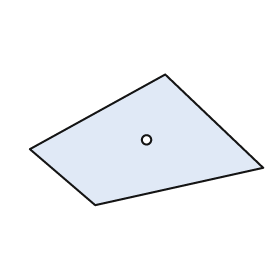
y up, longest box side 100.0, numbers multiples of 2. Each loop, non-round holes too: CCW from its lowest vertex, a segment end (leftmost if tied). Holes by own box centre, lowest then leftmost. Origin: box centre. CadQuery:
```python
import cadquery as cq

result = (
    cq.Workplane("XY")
    .moveTo(-22.0, -28.0)
    .lineTo(50.0, -12.0)
    .lineTo(8.0, 28.0)
    .lineTo(-50.0, -4.0)
    .close()
    .moveTo(0.0, 0.0)
    .circle(2.0)
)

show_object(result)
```